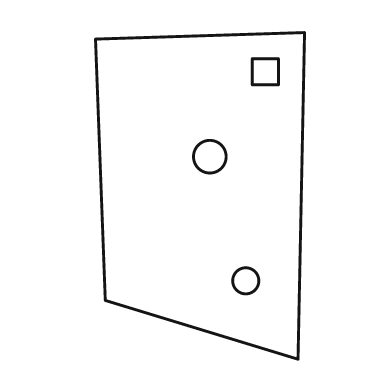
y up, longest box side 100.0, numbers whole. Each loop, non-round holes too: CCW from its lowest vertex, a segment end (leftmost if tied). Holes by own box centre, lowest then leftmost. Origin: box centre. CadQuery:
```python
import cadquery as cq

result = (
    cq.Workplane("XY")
    .moveTo(30.0, -50.0)
    .lineTo(32.0, 50.0)
    .lineTo(-32.0, 48.0)
    .lineTo(-29.0, -32.0)
    .close()
    .moveTo(14.0, -26.0)
    .circle(4.0)
    .moveTo(3.0, 12.0)
    .circle(5.0)
    .moveTo(16.0, 34.0)
    .lineTo(24.0, 34.0)
    .lineTo(24.0, 42.0)
    .lineTo(16.0, 42.0)
    .close()
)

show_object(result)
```